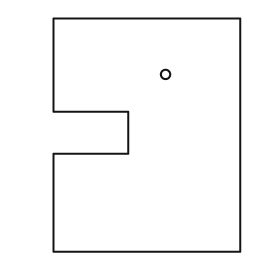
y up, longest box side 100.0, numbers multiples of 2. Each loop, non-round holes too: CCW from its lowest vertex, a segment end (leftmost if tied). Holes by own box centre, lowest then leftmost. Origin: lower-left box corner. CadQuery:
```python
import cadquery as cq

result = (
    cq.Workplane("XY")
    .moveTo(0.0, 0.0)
    .lineTo(80.0, 0.0)
    .lineTo(80.0, 100.0)
    .lineTo(0.0, 100.0)
    .lineTo(0.0, 60.0)
    .lineTo(32.0, 60.0)
    .lineTo(32.0, 42.0)
    .lineTo(0.0, 42.0)
    .close()
    .moveTo(48.0, 76.0)
    .circle(2.0)
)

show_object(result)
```